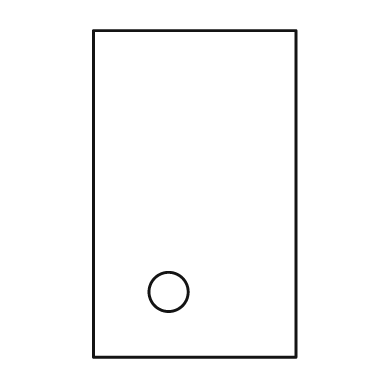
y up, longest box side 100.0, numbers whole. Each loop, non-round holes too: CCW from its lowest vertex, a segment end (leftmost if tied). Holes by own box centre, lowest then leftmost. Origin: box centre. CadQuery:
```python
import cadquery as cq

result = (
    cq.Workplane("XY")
    .moveTo(-31.0, -50.0)
    .lineTo(31.0, -50.0)
    .lineTo(31.0, 50.0)
    .lineTo(-31.0, 50.0)
    .close()
    .moveTo(-8.0, -30.0)
    .circle(6.0)
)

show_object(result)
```